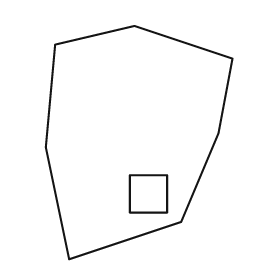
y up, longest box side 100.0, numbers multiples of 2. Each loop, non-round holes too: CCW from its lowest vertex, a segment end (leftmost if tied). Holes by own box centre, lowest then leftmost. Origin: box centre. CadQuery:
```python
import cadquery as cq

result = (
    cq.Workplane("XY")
    .moveTo(-30.0, -50.0)
    .lineTo(18.0, -34.0)
    .lineTo(34.0, 4.0)
    .lineTo(40.0, 36.0)
    .lineTo(-2.0, 50.0)
    .lineTo(-36.0, 42.0)
    .lineTo(-40.0, -2.0)
    .close()
    .moveTo(-4.0, -30.0)
    .lineTo(12.0, -30.0)
    .lineTo(12.0, -14.0)
    .lineTo(-4.0, -14.0)
    .close()
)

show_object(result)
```